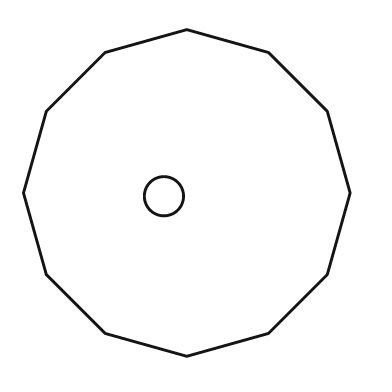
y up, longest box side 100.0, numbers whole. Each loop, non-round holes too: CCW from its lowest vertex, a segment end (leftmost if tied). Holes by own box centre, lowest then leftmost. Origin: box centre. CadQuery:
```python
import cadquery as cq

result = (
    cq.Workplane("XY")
    .moveTo(0.0, -50.0)
    .lineTo(25.0, -43.0)
    .lineTo(43.0, -25.0)
    .lineTo(50.0, 0.0)
    .lineTo(43.0, 25.0)
    .lineTo(25.0, 43.0)
    .lineTo(0.0, 50.0)
    .lineTo(-25.0, 43.0)
    .lineTo(-43.0, 25.0)
    .lineTo(-50.0, 0.0)
    .lineTo(-43.0, -25.0)
    .lineTo(-25.0, -43.0)
    .close()
    .moveTo(-7.0, -1.0)
    .circle(6.0)
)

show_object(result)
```